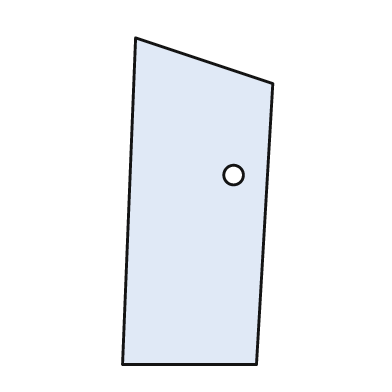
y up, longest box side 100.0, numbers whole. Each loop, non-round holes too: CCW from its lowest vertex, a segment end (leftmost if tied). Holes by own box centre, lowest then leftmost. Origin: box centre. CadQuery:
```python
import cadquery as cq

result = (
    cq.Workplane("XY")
    .moveTo(-23.0, -50.0)
    .lineTo(18.0, -50.0)
    .lineTo(23.0, 36.0)
    .lineTo(-19.0, 50.0)
    .close()
    .moveTo(11.0, 8.0)
    .circle(3.0)
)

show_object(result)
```